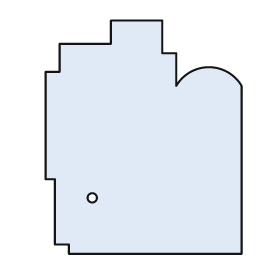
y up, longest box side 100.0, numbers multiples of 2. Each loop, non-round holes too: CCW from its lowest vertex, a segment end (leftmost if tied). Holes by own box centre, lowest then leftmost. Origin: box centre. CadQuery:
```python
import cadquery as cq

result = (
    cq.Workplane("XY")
    .moveTo(-32.0, -50.0)
    .lineTo(42.0, -50.0)
    .lineTo(42.0, 22.0)
    .threePointArc((28.0, 30.0), (14.0, 22.0))
    .lineTo(14.0, 36.0)
    .lineTo(8.0, 36.0)
    .lineTo(8.0, 50.0)
    .lineTo(-14.0, 50.0)
    .lineTo(-14.0, 40.0)
    .lineTo(-36.0, 40.0)
    .lineTo(-36.0, 28.0)
    .lineTo(-42.0, 28.0)
    .lineTo(-42.0, -18.0)
    .lineTo(-38.0, -18.0)
    .lineTo(-38.0, -46.0)
    .lineTo(-32.0, -46.0)
    .close()
    .moveTo(-22.0, -26.0)
    .circle(2.0)
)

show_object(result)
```